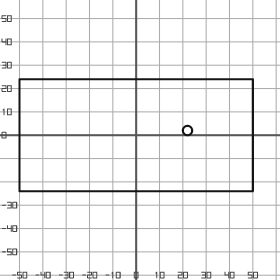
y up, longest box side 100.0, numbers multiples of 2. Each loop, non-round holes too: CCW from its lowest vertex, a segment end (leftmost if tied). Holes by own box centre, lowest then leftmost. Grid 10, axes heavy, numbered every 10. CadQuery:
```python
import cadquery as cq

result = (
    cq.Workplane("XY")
    .moveTo(-50.0, -24.0)
    .lineTo(50.0, -24.0)
    .lineTo(50.0, 24.0)
    .lineTo(-50.0, 24.0)
    .close()
    .moveTo(22.0, 2.0)
    .circle(2.0)
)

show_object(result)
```